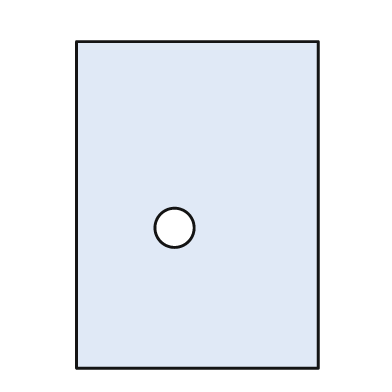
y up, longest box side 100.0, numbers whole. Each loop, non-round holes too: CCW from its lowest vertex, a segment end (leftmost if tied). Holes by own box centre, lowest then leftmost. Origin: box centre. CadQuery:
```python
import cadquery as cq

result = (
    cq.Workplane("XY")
    .moveTo(-37.0, -50.0)
    .lineTo(37.0, -50.0)
    .lineTo(37.0, 50.0)
    .lineTo(-37.0, 50.0)
    .close()
    .moveTo(-7.0, -7.0)
    .circle(6.0)
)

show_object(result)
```